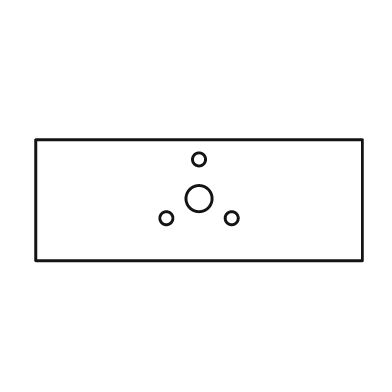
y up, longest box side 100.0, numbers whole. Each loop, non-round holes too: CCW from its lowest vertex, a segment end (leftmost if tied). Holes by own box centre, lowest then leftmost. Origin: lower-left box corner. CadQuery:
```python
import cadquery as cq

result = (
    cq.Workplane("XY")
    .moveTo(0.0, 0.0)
    .lineTo(100.0, 0.0)
    .lineTo(100.0, 37.0)
    .lineTo(0.0, 37.0)
    .close()
    .moveTo(40.0, 13.0)
    .circle(2.0)
    .moveTo(60.0, 13.0)
    .circle(2.0)
    .moveTo(50.0, 19.0)
    .circle(4.0)
    .moveTo(50.0, 31.0)
    .circle(2.0)
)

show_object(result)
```